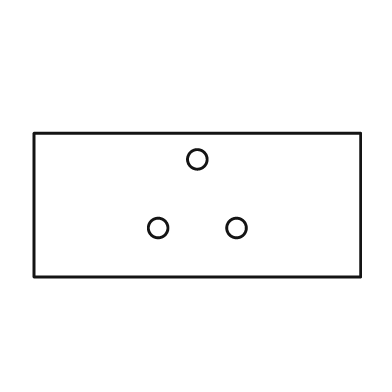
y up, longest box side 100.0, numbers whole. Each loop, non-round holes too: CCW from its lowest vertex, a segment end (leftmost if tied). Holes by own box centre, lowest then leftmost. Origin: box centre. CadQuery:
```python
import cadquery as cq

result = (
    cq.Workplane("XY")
    .moveTo(-50.0, -22.0)
    .lineTo(50.0, -22.0)
    .lineTo(50.0, 22.0)
    .lineTo(-50.0, 22.0)
    .close()
    .moveTo(-12.0, -7.0)
    .circle(3.0)
    .moveTo(12.0, -7.0)
    .circle(3.0)
    .moveTo(0.0, 14.0)
    .circle(3.0)
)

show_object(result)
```